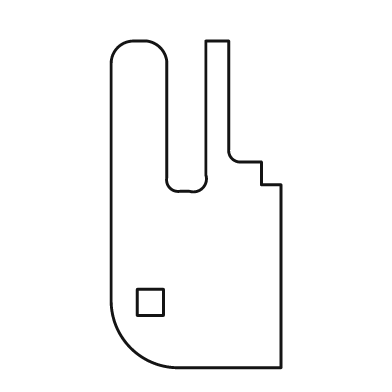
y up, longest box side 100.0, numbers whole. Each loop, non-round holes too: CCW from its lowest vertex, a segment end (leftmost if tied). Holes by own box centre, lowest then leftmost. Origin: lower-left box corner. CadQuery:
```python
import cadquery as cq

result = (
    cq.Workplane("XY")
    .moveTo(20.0, 0.0)
    .lineTo(52.0, 0.0)
    .lineTo(52.0, 56.0)
    .lineTo(46.0, 56.0)
    .lineTo(46.0, 63.0)
    .lineTo(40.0, 63.0)
    .threePointArc((37.0, 64.0), (36.0, 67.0))
    .lineTo(36.0, 100.0)
    .lineTo(29.0, 100.0)
    .lineTo(29.0, 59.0)
    .threePointArc((28.0, 55.0), (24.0, 54.0))
    .lineTo(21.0, 54.0)
    .threePointArc((18.0, 55.0), (17.0, 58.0))
    .lineTo(17.0, 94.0)
    .threePointArc((15.0, 98.0), (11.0, 100.0))
    .lineTo(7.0, 100.0)
    .threePointArc((2.0, 98.0), (0.0, 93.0))
    .lineTo(0.0, 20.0)
    .threePointArc((6.0, 6.0), (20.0, 0.0))
    .close()
    .moveTo(8.0, 16.0)
    .lineTo(16.0, 16.0)
    .lineTo(16.0, 24.0)
    .lineTo(8.0, 24.0)
    .close()
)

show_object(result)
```